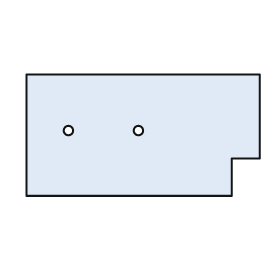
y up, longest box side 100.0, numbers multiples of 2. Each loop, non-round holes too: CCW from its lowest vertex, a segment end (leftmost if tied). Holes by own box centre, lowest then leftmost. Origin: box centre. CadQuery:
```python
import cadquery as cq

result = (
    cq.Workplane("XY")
    .moveTo(-50.0, -26.0)
    .lineTo(38.0, -26.0)
    .lineTo(38.0, -10.0)
    .lineTo(50.0, -10.0)
    .lineTo(50.0, 26.0)
    .lineTo(-50.0, 26.0)
    .close()
    .moveTo(-32.0, 2.0)
    .circle(2.0)
    .moveTo(-2.0, 2.0)
    .circle(2.0)
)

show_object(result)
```